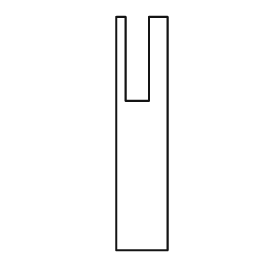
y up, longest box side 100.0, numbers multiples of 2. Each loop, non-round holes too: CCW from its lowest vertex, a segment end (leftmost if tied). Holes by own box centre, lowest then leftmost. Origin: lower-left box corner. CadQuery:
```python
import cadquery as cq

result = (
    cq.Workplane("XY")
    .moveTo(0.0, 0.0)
    .lineTo(22.0, 0.0)
    .lineTo(22.0, 100.0)
    .lineTo(14.0, 100.0)
    .lineTo(14.0, 64.0)
    .lineTo(4.0, 64.0)
    .lineTo(4.0, 100.0)
    .lineTo(0.0, 100.0)
    .close()
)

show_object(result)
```